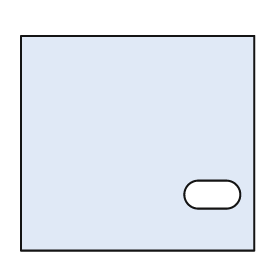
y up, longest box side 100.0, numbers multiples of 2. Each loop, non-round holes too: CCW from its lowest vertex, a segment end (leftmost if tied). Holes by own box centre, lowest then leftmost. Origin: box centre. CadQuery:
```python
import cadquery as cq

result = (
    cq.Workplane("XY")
    .moveTo(-50.0, -46.0)
    .lineTo(50.0, -46.0)
    .lineTo(50.0, 46.0)
    .lineTo(-50.0, 46.0)
    .close()
    .moveTo(26.0, -28.0)
    .lineTo(38.0, -28.0)
    .threePointArc((44.0, -22.0), (38.0, -16.0))
    .lineTo(26.0, -16.0)
    .threePointArc((20.0, -22.0), (26.0, -28.0))
    .close()
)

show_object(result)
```